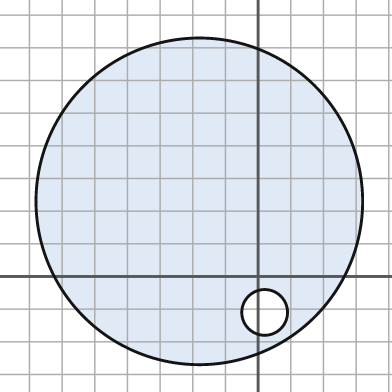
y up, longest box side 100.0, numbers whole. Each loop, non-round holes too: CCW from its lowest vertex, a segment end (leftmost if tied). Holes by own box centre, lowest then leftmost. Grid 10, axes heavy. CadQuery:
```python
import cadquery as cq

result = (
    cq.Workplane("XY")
    .moveTo(-18.0, 23.0)
    .circle(50.0)
    .moveTo(2.0, -11.0)
    .circle(7.0)
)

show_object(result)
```